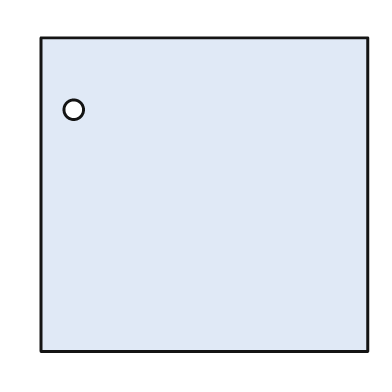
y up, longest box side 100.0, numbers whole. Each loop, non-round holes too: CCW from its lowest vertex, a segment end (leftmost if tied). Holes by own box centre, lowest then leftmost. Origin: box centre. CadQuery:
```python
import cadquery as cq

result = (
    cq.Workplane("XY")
    .moveTo(-50.0, -48.0)
    .lineTo(50.0, -48.0)
    .lineTo(50.0, 48.0)
    .lineTo(-50.0, 48.0)
    .close()
    .moveTo(-40.0, 26.0)
    .circle(3.0)
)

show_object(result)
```